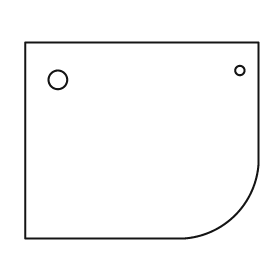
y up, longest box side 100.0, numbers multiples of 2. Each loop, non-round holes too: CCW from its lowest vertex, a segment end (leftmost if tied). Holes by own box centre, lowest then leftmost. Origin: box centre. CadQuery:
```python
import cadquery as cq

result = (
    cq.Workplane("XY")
    .moveTo(-50.0, -42.0)
    .lineTo(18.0, -42.0)
    .threePointArc((40.0, -32.0), (50.0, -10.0))
    .lineTo(50.0, 42.0)
    .lineTo(-50.0, 42.0)
    .close()
    .moveTo(-36.0, 26.0)
    .circle(4.0)
    .moveTo(42.0, 30.0)
    .circle(2.0)
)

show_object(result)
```